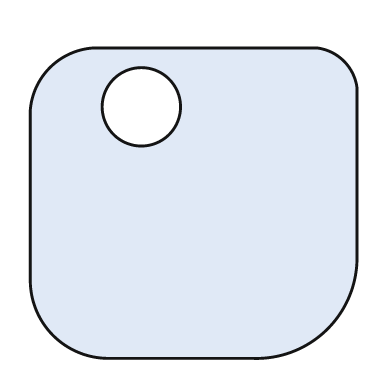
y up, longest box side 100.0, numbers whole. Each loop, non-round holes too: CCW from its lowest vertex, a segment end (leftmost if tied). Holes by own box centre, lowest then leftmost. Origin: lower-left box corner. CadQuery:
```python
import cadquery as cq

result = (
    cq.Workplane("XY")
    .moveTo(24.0, 0.0)
    .lineTo(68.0, 0.0)
    .threePointArc((91.0, 9.0), (100.0, 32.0))
    .lineTo(100.0, 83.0)
    .threePointArc((96.0, 91.0), (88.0, 95.0))
    .lineTo(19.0, 95.0)
    .threePointArc((6.0, 89.0), (0.0, 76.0))
    .lineTo(0.0, 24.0)
    .threePointArc((7.0, 7.0), (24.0, 0.0))
    .close()
    .moveTo(34.0, 77.0)
    .circle(12.0)
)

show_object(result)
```